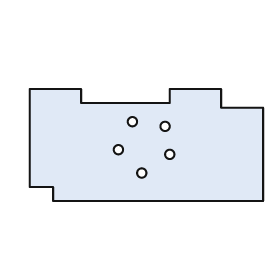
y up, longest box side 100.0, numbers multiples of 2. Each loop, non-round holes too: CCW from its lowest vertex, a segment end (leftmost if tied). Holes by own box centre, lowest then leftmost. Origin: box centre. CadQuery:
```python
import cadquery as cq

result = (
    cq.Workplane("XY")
    .moveTo(-40.0, -24.0)
    .lineTo(50.0, -24.0)
    .lineTo(50.0, 16.0)
    .lineTo(32.0, 16.0)
    .lineTo(32.0, 24.0)
    .lineTo(10.0, 24.0)
    .lineTo(10.0, 18.0)
    .lineTo(-28.0, 18.0)
    .lineTo(-28.0, 24.0)
    .lineTo(-50.0, 24.0)
    .lineTo(-50.0, -18.0)
    .lineTo(-40.0, -18.0)
    .close()
    .moveTo(-2.0, -12.0)
    .circle(2.0)
    .moveTo(10.0, -4.0)
    .circle(2.0)
    .moveTo(-12.0, -2.0)
    .circle(2.0)
    .moveTo(8.0, 8.0)
    .circle(2.0)
    .moveTo(-6.0, 10.0)
    .circle(2.0)
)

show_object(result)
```